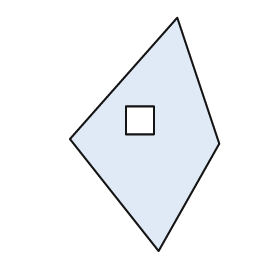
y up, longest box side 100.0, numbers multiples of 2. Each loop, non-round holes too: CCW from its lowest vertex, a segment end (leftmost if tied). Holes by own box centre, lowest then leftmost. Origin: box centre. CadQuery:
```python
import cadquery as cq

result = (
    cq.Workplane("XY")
    .moveTo(6.0, -50.0)
    .lineTo(32.0, -4.0)
    .lineTo(14.0, 50.0)
    .lineTo(-32.0, -2.0)
    .close()
    .moveTo(-8.0, 0.0)
    .lineTo(4.0, 0.0)
    .lineTo(4.0, 12.0)
    .lineTo(-8.0, 12.0)
    .close()
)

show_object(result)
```